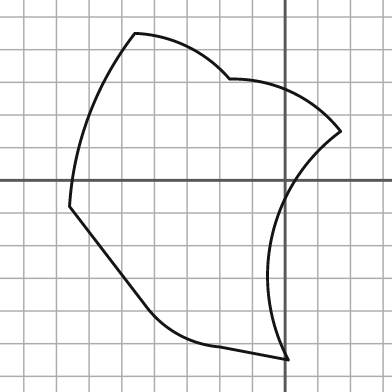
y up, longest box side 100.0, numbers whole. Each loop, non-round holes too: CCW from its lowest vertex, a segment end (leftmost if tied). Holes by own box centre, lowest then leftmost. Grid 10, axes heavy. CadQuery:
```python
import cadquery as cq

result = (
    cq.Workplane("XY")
    .moveTo(1.0, -55.0)
    .threePointArc((-4.0, -17.0), (17.0, 15.0))
    .threePointArc((2.0, 27.0), (-17.0, 31.0))
    .threePointArc((-30.0, 41.0), (-46.0, 45.0))
    .threePointArc((-60.0, 20.0), (-66.0, -8.0))
    .lineTo(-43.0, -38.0)
    .threePointArc((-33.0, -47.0), (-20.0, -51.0))
    .close()
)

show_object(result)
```